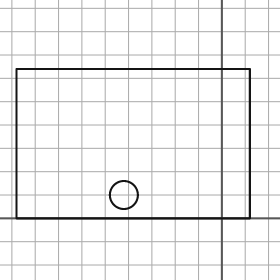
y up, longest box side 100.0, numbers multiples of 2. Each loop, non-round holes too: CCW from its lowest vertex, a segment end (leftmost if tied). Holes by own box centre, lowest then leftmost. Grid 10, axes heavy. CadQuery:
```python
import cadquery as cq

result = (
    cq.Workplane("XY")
    .moveTo(-88.0, 0.0)
    .lineTo(12.0, 0.0)
    .lineTo(12.0, 64.0)
    .lineTo(-88.0, 64.0)
    .close()
    .moveTo(-42.0, 10.0)
    .circle(6.0)
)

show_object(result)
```